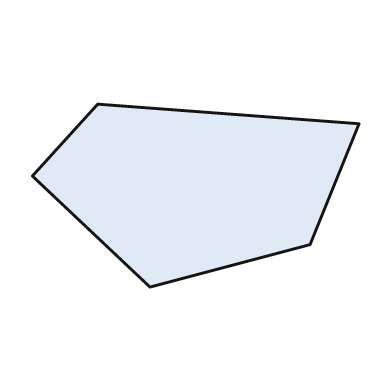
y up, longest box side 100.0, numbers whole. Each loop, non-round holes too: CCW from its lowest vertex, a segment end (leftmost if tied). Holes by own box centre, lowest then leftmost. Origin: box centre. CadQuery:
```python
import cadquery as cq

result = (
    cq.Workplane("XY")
    .moveTo(-14.0, -28.0)
    .lineTo(35.0, -15.0)
    .lineTo(50.0, 22.0)
    .lineTo(-30.0, 28.0)
    .lineTo(-50.0, 6.0)
    .close()
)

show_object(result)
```